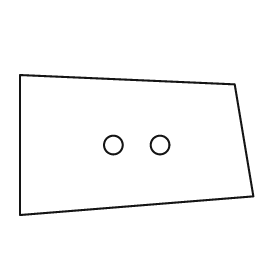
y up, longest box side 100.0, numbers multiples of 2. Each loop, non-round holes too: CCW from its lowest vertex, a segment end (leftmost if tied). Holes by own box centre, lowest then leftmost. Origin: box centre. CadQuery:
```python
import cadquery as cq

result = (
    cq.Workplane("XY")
    .moveTo(-50.0, -30.0)
    .lineTo(50.0, -22.0)
    .lineTo(42.0, 26.0)
    .lineTo(-50.0, 30.0)
    .close()
    .moveTo(-10.0, 0.0)
    .circle(4.0)
    .moveTo(10.0, 0.0)
    .circle(4.0)
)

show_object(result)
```